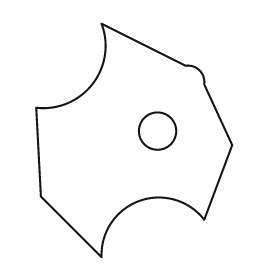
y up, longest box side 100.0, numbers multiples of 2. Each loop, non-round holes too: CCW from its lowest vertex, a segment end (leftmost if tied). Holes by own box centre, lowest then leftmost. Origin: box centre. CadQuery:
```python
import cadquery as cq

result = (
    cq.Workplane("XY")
    .moveTo(-14.0, -50.0)
    .threePointArc((2.0, -26.0), (30.0, -34.0))
    .lineTo(42.0, -2.0)
    .lineTo(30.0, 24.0)
    .threePointArc((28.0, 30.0), (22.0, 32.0))
    .lineTo(-14.0, 50.0)
    .threePointArc((-18.0, 24.0), (-42.0, 14.0))
    .lineTo(-40.0, -24.0)
    .close()
    .moveTo(10.0, 4.0)
    .circle(8.0)
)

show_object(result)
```